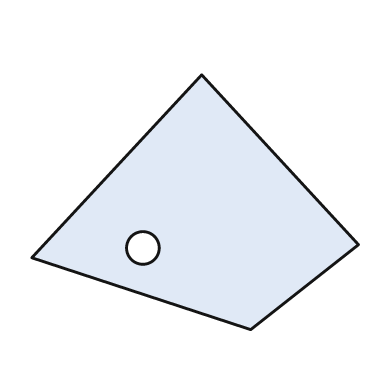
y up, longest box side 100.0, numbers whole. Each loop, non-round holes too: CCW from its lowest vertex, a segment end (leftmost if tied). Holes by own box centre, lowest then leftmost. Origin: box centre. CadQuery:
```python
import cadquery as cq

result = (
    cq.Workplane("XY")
    .moveTo(17.0, -39.0)
    .lineTo(50.0, -13.0)
    .lineTo(2.0, 39.0)
    .lineTo(-50.0, -17.0)
    .close()
    .moveTo(-16.0, -14.0)
    .circle(5.0)
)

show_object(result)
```